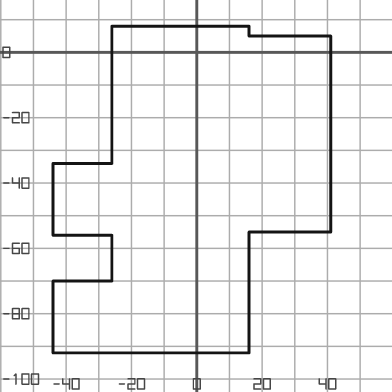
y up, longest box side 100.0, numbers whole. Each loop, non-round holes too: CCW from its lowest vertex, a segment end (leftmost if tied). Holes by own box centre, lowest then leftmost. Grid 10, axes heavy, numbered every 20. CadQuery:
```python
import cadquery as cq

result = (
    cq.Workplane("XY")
    .moveTo(-44.0, -92.0)
    .lineTo(16.0, -92.0)
    .lineTo(16.0, -55.0)
    .lineTo(41.0, -55.0)
    .lineTo(41.0, 5.0)
    .lineTo(16.0, 5.0)
    .lineTo(16.0, 8.0)
    .lineTo(-26.0, 8.0)
    .lineTo(-26.0, -34.0)
    .lineTo(-44.0, -34.0)
    .lineTo(-44.0, -56.0)
    .lineTo(-26.0, -56.0)
    .lineTo(-26.0, -70.0)
    .lineTo(-44.0, -70.0)
    .close()
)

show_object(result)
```